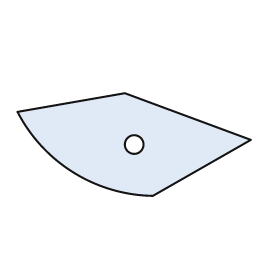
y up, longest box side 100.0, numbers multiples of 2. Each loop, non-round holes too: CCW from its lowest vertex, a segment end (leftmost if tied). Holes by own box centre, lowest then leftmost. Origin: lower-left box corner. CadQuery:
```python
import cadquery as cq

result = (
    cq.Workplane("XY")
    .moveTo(58.0, 0.0)
    .lineTo(100.0, 24.0)
    .lineTo(46.0, 44.0)
    .lineTo(0.0, 36.0)
    .threePointArc((24.0, 10.0), (58.0, 0.0))
    .close()
    .moveTo(50.0, 22.0)
    .circle(4.0)
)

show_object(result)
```